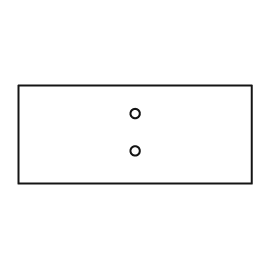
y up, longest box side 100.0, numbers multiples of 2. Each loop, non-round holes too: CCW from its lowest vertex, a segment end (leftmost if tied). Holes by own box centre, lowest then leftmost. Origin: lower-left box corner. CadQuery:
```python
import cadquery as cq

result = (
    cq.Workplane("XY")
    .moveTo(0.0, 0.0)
    .lineTo(100.0, 0.0)
    .lineTo(100.0, 42.0)
    .lineTo(0.0, 42.0)
    .close()
    .moveTo(50.0, 14.0)
    .circle(2.0)
    .moveTo(50.0, 30.0)
    .circle(2.0)
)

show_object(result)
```